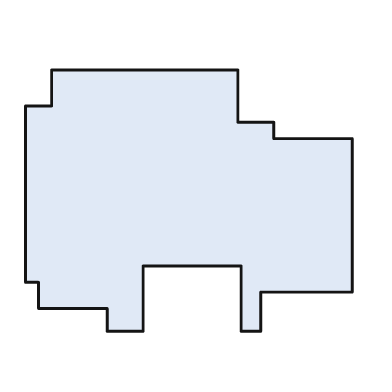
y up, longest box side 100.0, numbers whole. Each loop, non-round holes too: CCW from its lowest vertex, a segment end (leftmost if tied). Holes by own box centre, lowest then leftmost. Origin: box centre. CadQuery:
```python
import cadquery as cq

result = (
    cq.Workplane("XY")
    .moveTo(-25.0, -40.0)
    .lineTo(-14.0, -40.0)
    .lineTo(-14.0, -20.0)
    .lineTo(16.0, -20.0)
    .lineTo(16.0, -40.0)
    .lineTo(22.0, -40.0)
    .lineTo(22.0, -28.0)
    .lineTo(50.0, -28.0)
    .lineTo(50.0, 19.0)
    .lineTo(26.0, 19.0)
    .lineTo(26.0, 24.0)
    .lineTo(15.0, 24.0)
    .lineTo(15.0, 40.0)
    .lineTo(-42.0, 40.0)
    .lineTo(-42.0, 29.0)
    .lineTo(-50.0, 29.0)
    .lineTo(-50.0, -25.0)
    .lineTo(-46.0, -25.0)
    .lineTo(-46.0, -33.0)
    .lineTo(-25.0, -33.0)
    .close()
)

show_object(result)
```